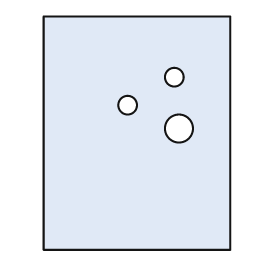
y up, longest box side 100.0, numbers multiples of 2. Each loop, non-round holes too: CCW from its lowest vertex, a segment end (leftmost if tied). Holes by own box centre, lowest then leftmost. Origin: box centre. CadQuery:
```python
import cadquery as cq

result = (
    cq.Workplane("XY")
    .moveTo(-40.0, -50.0)
    .lineTo(40.0, -50.0)
    .lineTo(40.0, 50.0)
    .lineTo(-40.0, 50.0)
    .close()
    .moveTo(18.0, 2.0)
    .circle(6.0)
    .moveTo(-4.0, 12.0)
    .circle(4.0)
    .moveTo(16.0, 24.0)
    .circle(4.0)
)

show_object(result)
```